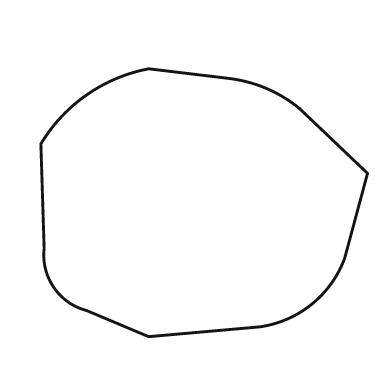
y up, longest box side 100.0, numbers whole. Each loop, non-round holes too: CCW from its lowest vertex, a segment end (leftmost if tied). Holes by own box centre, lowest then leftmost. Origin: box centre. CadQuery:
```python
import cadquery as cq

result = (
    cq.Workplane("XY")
    .moveTo(-17.0, -41.0)
    .lineTo(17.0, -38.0)
    .threePointArc((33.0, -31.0), (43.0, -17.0))
    .lineTo(50.0, 9.0)
    .lineTo(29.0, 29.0)
    .threePointArc((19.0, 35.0), (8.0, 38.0))
    .lineTo(-17.0, 41.0)
    .threePointArc((-36.0, 33.0), (-50.0, 18.0))
    .lineTo(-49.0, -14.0)
    .threePointArc((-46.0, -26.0), (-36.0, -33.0))
    .close()
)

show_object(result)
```